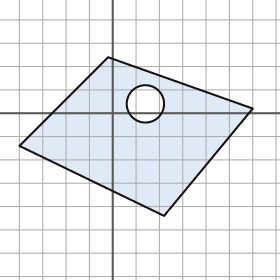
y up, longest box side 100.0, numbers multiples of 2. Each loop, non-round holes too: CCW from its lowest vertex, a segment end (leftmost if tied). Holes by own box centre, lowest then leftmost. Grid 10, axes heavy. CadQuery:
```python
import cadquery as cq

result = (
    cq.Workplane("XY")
    .moveTo(22.0, -44.0)
    .lineTo(60.0, 2.0)
    .lineTo(-2.0, 24.0)
    .lineTo(-40.0, -14.0)
    .close()
    .moveTo(14.0, 4.0)
    .circle(8.0)
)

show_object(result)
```